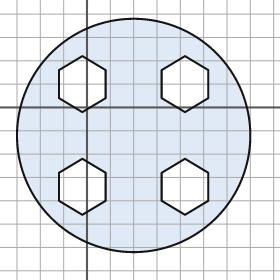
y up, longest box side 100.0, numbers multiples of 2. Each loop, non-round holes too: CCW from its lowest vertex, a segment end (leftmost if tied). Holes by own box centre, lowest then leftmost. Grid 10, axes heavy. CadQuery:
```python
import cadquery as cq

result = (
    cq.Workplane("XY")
    .moveTo(20.0, -12.0)
    .circle(50.0)
    .moveTo(-2.0, -46.0)
    .lineTo(8.0, -40.0)
    .lineTo(8.0, -28.0)
    .lineTo(-2.0, -22.0)
    .lineTo(-12.0, -28.0)
    .lineTo(-12.0, -40.0)
    .close()
    .moveTo(42.0, -46.0)
    .lineTo(52.0, -40.0)
    .lineTo(52.0, -28.0)
    .lineTo(42.0, -22.0)
    .lineTo(32.0, -28.0)
    .lineTo(32.0, -40.0)
    .close()
    .moveTo(-2.0, -2.0)
    .lineTo(8.0, 4.0)
    .lineTo(8.0, 16.0)
    .lineTo(-2.0, 22.0)
    .lineTo(-12.0, 16.0)
    .lineTo(-12.0, 4.0)
    .close()
    .moveTo(42.0, -2.0)
    .lineTo(52.0, 4.0)
    .lineTo(52.0, 16.0)
    .lineTo(42.0, 22.0)
    .lineTo(32.0, 16.0)
    .lineTo(32.0, 4.0)
    .close()
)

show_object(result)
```